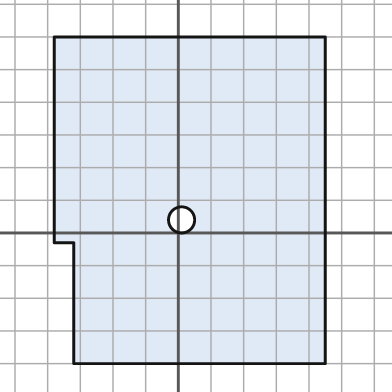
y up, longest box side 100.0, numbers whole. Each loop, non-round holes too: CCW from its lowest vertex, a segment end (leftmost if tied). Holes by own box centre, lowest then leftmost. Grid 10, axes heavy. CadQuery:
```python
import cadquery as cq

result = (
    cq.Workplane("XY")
    .moveTo(-32.0, -40.0)
    .lineTo(45.0, -40.0)
    .lineTo(45.0, 60.0)
    .lineTo(-38.0, 60.0)
    .lineTo(-38.0, -3.0)
    .lineTo(-32.0, -3.0)
    .close()
    .moveTo(1.0, 4.0)
    .circle(4.0)
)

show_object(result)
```